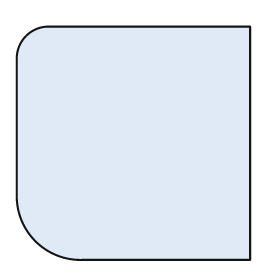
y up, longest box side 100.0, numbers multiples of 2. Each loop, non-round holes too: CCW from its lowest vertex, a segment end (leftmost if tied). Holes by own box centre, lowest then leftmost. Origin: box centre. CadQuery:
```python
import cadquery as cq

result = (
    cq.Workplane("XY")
    .moveTo(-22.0, -50.0)
    .lineTo(50.0, -50.0)
    .lineTo(50.0, 50.0)
    .lineTo(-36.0, 50.0)
    .threePointArc((-46.0, 46.0), (-50.0, 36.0))
    .lineTo(-50.0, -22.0)
    .threePointArc((-42.0, -42.0), (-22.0, -50.0))
    .close()
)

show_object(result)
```